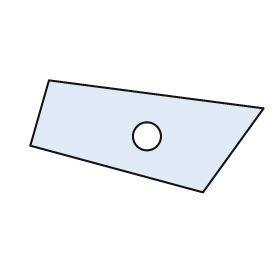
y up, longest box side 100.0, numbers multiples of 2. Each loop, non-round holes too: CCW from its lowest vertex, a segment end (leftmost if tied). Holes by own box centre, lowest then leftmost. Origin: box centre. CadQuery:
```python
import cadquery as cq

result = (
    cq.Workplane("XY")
    .moveTo(24.0, -24.0)
    .lineTo(50.0, 12.0)
    .lineTo(-42.0, 24.0)
    .lineTo(-50.0, -4.0)
    .close()
    .moveTo(0.0, 0.0)
    .circle(6.0)
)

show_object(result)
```